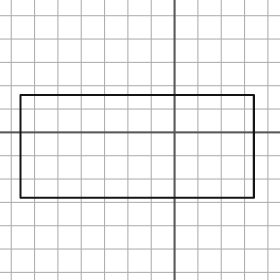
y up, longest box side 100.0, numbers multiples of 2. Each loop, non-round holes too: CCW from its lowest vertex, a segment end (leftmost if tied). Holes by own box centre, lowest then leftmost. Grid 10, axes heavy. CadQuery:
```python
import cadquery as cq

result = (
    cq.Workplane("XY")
    .moveTo(-66.0, -28.0)
    .lineTo(34.0, -28.0)
    .lineTo(34.0, 16.0)
    .lineTo(-66.0, 16.0)
    .close()
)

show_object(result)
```